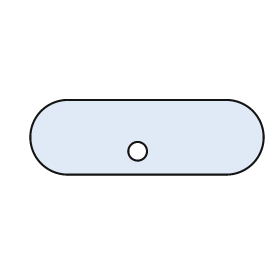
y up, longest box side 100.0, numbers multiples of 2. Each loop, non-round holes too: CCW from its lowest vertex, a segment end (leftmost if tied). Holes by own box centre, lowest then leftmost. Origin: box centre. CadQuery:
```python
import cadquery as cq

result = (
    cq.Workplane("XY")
    .moveTo(-34.0, -16.0)
    .lineTo(34.0, -16.0)
    .threePointArc((50.0, 0.0), (34.0, 16.0))
    .lineTo(-34.0, 16.0)
    .threePointArc((-50.0, 0.0), (-34.0, -16.0))
    .close()
    .moveTo(-4.0, -6.0)
    .circle(4.0)
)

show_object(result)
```